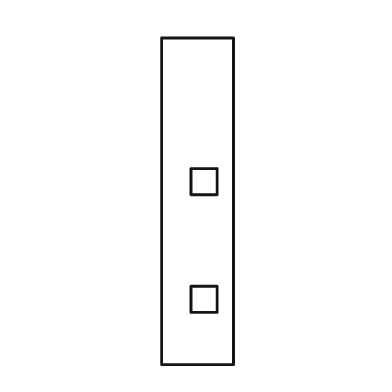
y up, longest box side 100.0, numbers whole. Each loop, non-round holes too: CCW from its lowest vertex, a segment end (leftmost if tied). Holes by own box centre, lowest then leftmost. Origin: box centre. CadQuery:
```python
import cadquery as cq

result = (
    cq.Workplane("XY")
    .moveTo(-11.0, -50.0)
    .lineTo(11.0, -50.0)
    .lineTo(11.0, 50.0)
    .lineTo(-11.0, 50.0)
    .close()
    .moveTo(-2.0, -34.0)
    .lineTo(6.0, -34.0)
    .lineTo(6.0, -26.0)
    .lineTo(-2.0, -26.0)
    .close()
    .moveTo(-2.0, 2.0)
    .lineTo(6.0, 2.0)
    .lineTo(6.0, 10.0)
    .lineTo(-2.0, 10.0)
    .close()
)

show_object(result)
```